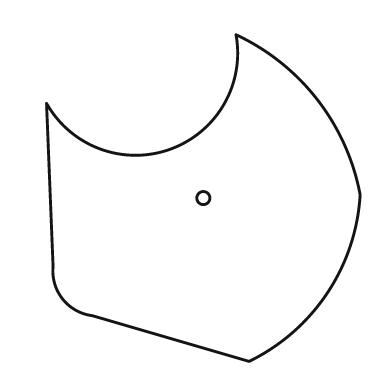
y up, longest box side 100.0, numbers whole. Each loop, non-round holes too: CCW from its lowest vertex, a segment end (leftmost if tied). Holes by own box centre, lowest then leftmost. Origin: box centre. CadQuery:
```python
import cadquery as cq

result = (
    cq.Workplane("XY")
    .moveTo(14.0, -50.0)
    .threePointArc((38.0, -29.0), (48.0, 1.0))
    .threePointArc((35.0, 30.0), (10.0, 50.0))
    .threePointArc((-10.0, 15.0), (-48.0, 29.0))
    .lineTo(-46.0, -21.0)
    .threePointArc((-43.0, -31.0), (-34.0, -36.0))
    .close()
    .moveTo(0.0, 0.0)
    .circle(2.0)
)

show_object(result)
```